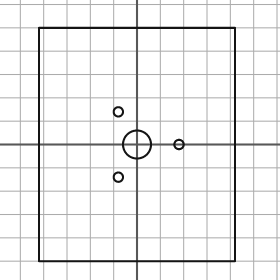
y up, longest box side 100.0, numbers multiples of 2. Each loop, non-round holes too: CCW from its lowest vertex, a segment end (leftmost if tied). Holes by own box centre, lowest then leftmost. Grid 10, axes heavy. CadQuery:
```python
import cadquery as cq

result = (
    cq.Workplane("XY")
    .moveTo(-42.0, -50.0)
    .lineTo(42.0, -50.0)
    .lineTo(42.0, 50.0)
    .lineTo(-42.0, 50.0)
    .close()
    .moveTo(-8.0, -14.0)
    .circle(2.0)
    .moveTo(0.0, 0.0)
    .circle(6.0)
    .moveTo(18.0, 0.0)
    .circle(2.0)
    .moveTo(-8.0, 14.0)
    .circle(2.0)
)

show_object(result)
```